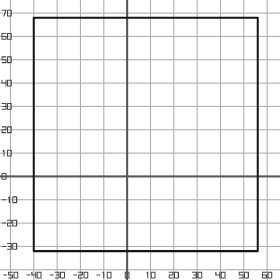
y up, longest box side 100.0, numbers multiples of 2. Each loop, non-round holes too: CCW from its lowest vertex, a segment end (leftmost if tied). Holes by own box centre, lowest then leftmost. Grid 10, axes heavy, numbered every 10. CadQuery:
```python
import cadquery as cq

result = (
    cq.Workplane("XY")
    .moveTo(-40.0, -32.0)
    .lineTo(56.0, -32.0)
    .lineTo(56.0, 68.0)
    .lineTo(-40.0, 68.0)
    .close()
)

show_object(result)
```